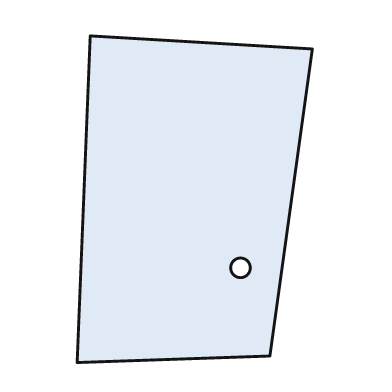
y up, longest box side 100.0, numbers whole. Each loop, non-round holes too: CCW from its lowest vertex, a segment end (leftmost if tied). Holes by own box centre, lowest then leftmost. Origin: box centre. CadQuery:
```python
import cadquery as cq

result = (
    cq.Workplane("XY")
    .moveTo(-36.0, -50.0)
    .lineTo(23.0, -48.0)
    .lineTo(36.0, 46.0)
    .lineTo(-32.0, 50.0)
    .close()
    .moveTo(14.0, -21.0)
    .circle(3.0)
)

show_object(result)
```